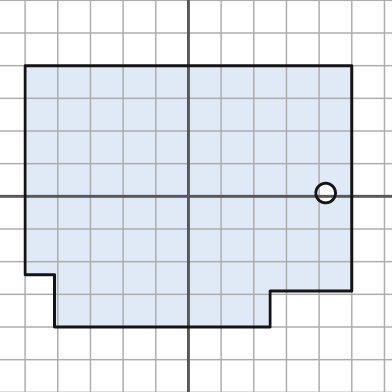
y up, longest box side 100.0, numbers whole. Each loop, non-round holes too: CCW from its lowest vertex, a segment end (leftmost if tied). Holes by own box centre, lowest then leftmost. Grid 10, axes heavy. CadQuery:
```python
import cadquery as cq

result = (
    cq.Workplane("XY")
    .moveTo(-41.0, -40.0)
    .lineTo(25.0, -40.0)
    .lineTo(25.0, -29.0)
    .lineTo(50.0, -29.0)
    .lineTo(50.0, 40.0)
    .lineTo(-50.0, 40.0)
    .lineTo(-50.0, -24.0)
    .lineTo(-41.0, -24.0)
    .close()
    .moveTo(42.0, 1.0)
    .circle(3.0)
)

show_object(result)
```